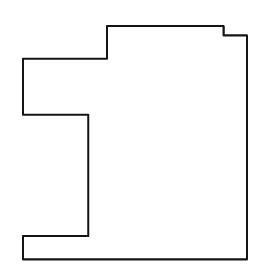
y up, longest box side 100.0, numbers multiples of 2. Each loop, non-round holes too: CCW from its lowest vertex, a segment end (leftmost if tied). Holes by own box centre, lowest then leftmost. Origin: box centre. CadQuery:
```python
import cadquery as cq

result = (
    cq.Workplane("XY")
    .moveTo(-48.0, -50.0)
    .lineTo(48.0, -50.0)
    .lineTo(48.0, 46.0)
    .lineTo(38.0, 46.0)
    .lineTo(38.0, 50.0)
    .lineTo(-12.0, 50.0)
    .lineTo(-12.0, 36.0)
    .lineTo(-48.0, 36.0)
    .lineTo(-48.0, 12.0)
    .lineTo(-20.0, 12.0)
    .lineTo(-20.0, -40.0)
    .lineTo(-48.0, -40.0)
    .close()
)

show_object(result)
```